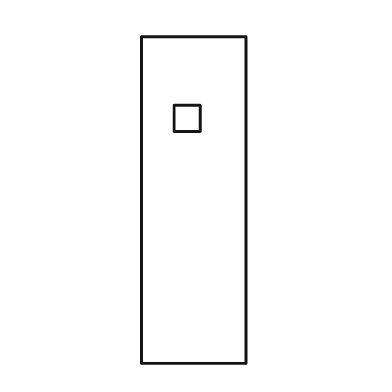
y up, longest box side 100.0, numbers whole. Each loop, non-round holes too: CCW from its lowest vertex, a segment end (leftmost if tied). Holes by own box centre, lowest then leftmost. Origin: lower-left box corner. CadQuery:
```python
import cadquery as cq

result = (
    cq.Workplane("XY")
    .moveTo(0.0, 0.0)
    .lineTo(32.0, 0.0)
    .lineTo(32.0, 100.0)
    .lineTo(0.0, 100.0)
    .close()
    .moveTo(10.0, 71.0)
    .lineTo(18.0, 71.0)
    .lineTo(18.0, 79.0)
    .lineTo(10.0, 79.0)
    .close()
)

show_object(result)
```